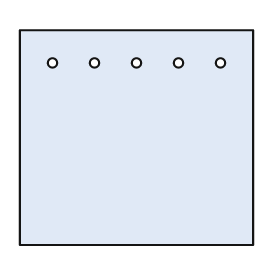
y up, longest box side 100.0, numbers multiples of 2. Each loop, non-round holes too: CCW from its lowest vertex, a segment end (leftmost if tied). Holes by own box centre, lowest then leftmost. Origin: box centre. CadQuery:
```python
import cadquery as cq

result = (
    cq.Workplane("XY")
    .moveTo(-50.0, -46.0)
    .lineTo(50.0, -46.0)
    .lineTo(50.0, 46.0)
    .lineTo(-50.0, 46.0)
    .close()
    .moveTo(-36.0, 32.0)
    .circle(2.0)
    .moveTo(-18.0, 32.0)
    .circle(2.0)
    .moveTo(0.0, 32.0)
    .circle(2.0)
    .moveTo(18.0, 32.0)
    .circle(2.0)
    .moveTo(36.0, 32.0)
    .circle(2.0)
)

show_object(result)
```